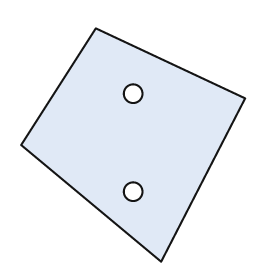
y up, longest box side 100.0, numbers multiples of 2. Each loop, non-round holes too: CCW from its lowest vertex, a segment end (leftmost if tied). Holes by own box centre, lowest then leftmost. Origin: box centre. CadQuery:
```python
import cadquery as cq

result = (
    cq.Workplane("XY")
    .moveTo(12.0, -50.0)
    .lineTo(48.0, 20.0)
    .lineTo(-16.0, 50.0)
    .lineTo(-48.0, 0.0)
    .close()
    .moveTo(0.0, -20.0)
    .circle(4.0)
    .moveTo(0.0, 22.0)
    .circle(4.0)
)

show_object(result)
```